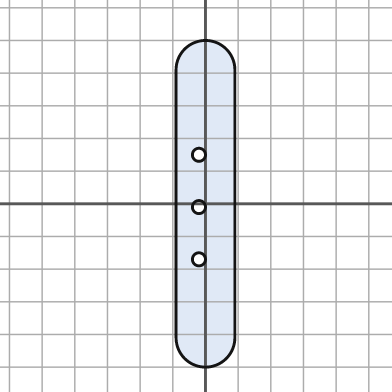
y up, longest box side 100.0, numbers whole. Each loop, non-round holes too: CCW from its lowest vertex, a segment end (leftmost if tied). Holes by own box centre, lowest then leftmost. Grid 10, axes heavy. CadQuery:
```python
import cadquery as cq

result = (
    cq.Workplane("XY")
    .moveTo(-9.0, -41.0)
    .threePointArc((0.0, -50.0), (9.0, -41.0))
    .lineTo(9.0, 41.0)
    .threePointArc((0.0, 50.0), (-9.0, 41.0))
    .close()
    .moveTo(-2.0, -17.0)
    .circle(2.0)
    .moveTo(-2.0, -1.0)
    .circle(2.0)
    .moveTo(-2.0, 15.0)
    .circle(2.0)
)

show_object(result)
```